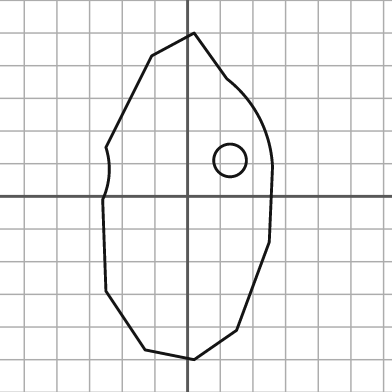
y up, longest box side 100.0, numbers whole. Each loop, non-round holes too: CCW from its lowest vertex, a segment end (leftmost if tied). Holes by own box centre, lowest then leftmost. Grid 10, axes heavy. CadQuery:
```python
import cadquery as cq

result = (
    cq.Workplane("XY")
    .moveTo(2.0, -50.0)
    .lineTo(15.0, -41.0)
    .lineTo(25.0, -14.0)
    .lineTo(26.0, 9.0)
    .threePointArc((22.0, 24.0), (12.0, 36.0))
    .lineTo(2.0, 50.0)
    .lineTo(-11.0, 43.0)
    .lineTo(-25.0, 15.0)
    .threePointArc((-24.0, 7.0), (-26.0, -1.0))
    .lineTo(-25.0, -29.0)
    .lineTo(-13.0, -47.0)
    .close()
    .moveTo(13.0, 11.0)
    .circle(5.0)
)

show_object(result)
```